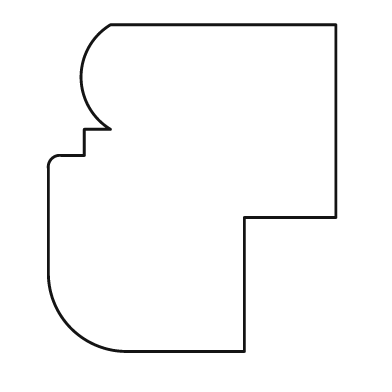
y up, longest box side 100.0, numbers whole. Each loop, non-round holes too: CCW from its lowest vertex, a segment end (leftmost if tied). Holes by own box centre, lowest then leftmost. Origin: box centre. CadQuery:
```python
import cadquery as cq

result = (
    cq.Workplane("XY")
    .moveTo(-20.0, -50.0)
    .lineTo(16.0, -50.0)
    .lineTo(16.0, -9.0)
    .lineTo(44.0, -9.0)
    .lineTo(44.0, 50.0)
    .lineTo(-25.0, 50.0)
    .threePointArc((-34.0, 34.0), (-25.0, 18.0))
    .lineTo(-33.0, 18.0)
    .lineTo(-33.0, 10.0)
    .lineTo(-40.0, 10.0)
    .threePointArc((-43.0, 9.0), (-44.0, 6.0))
    .lineTo(-44.0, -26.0)
    .threePointArc((-37.0, -43.0), (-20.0, -50.0))
    .close()
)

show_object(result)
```